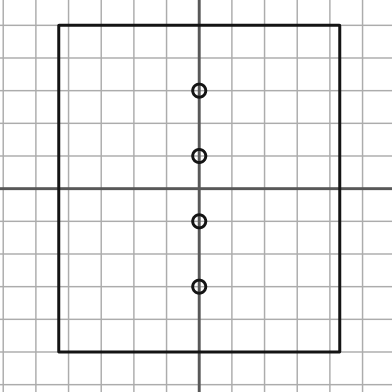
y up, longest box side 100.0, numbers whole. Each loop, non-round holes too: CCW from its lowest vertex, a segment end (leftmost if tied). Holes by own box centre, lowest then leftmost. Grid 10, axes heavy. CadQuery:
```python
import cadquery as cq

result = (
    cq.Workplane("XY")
    .moveTo(-43.0, -50.0)
    .lineTo(43.0, -50.0)
    .lineTo(43.0, 50.0)
    .lineTo(-43.0, 50.0)
    .close()
    .moveTo(0.0, -30.0)
    .circle(2.0)
    .moveTo(0.0, -10.0)
    .circle(2.0)
    .moveTo(0.0, 10.0)
    .circle(2.0)
    .moveTo(0.0, 30.0)
    .circle(2.0)
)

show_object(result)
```